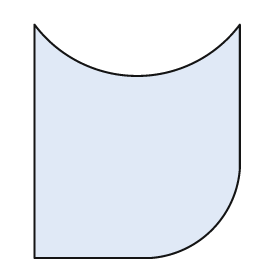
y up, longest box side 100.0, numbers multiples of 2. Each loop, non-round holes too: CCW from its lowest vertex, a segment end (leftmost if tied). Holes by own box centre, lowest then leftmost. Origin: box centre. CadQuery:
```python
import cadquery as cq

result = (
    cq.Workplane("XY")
    .moveTo(-44.0, -50.0)
    .lineTo(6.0, -50.0)
    .threePointArc((32.0, -38.0), (44.0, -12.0))
    .lineTo(44.0, 50.0)
    .threePointArc((0.0, 28.0), (-44.0, 50.0))
    .close()
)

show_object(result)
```